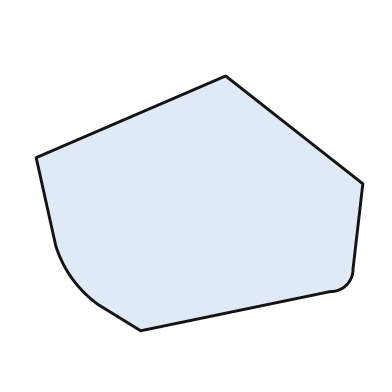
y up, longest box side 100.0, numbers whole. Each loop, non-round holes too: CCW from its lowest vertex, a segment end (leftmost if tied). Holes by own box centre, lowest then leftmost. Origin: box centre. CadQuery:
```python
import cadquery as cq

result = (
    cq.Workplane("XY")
    .moveTo(-18.0, -39.0)
    .lineTo(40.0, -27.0)
    .threePointArc((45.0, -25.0), (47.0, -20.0))
    .lineTo(50.0, 6.0)
    .lineTo(8.0, 39.0)
    .lineTo(-50.0, 14.0)
    .lineTo(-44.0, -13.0)
    .threePointArc((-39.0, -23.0), (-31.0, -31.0))
    .close()
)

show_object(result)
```